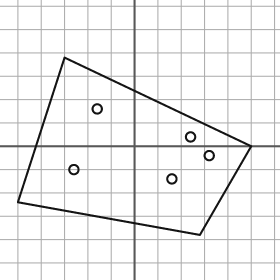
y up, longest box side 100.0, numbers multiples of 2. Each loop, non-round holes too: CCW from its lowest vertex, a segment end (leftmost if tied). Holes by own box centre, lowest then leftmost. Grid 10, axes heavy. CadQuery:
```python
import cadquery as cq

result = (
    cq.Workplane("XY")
    .moveTo(28.0, -38.0)
    .lineTo(50.0, 0.0)
    .lineTo(-30.0, 38.0)
    .lineTo(-50.0, -24.0)
    .close()
    .moveTo(16.0, -14.0)
    .circle(2.0)
    .moveTo(-26.0, -10.0)
    .circle(2.0)
    .moveTo(32.0, -4.0)
    .circle(2.0)
    .moveTo(24.0, 4.0)
    .circle(2.0)
    .moveTo(-16.0, 16.0)
    .circle(2.0)
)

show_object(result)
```